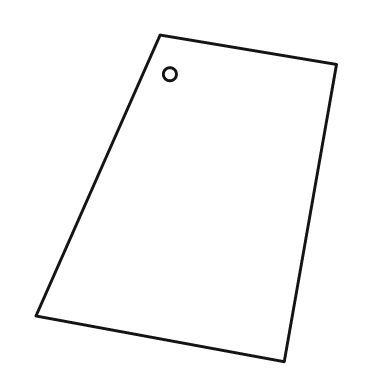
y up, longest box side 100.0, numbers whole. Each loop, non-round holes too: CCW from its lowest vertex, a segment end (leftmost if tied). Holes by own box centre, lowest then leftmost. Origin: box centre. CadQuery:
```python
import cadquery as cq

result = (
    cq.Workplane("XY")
    .moveTo(30.0, -50.0)
    .lineTo(46.0, 41.0)
    .lineTo(-8.0, 50.0)
    .lineTo(-46.0, -36.0)
    .close()
    .moveTo(-5.0, 38.0)
    .circle(2.0)
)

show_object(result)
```